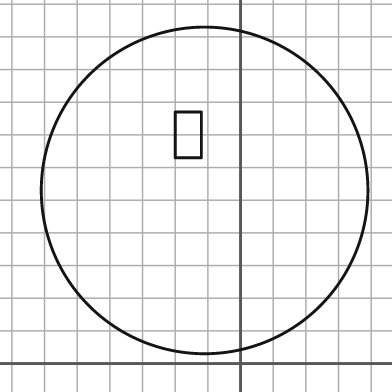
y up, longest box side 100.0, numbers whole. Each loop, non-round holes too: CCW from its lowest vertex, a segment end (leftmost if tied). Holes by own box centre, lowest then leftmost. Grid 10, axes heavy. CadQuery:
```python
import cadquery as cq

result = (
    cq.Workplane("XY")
    .moveTo(-11.0, 53.0)
    .circle(50.0)
    .moveTo(-20.0, 63.0)
    .lineTo(-12.0, 63.0)
    .lineTo(-12.0, 77.0)
    .lineTo(-20.0, 77.0)
    .close()
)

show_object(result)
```